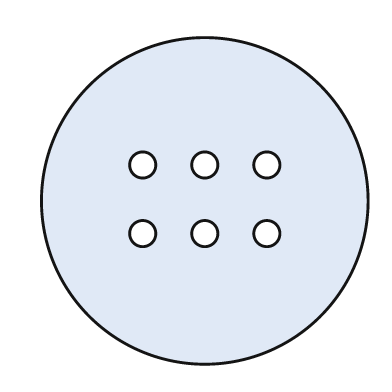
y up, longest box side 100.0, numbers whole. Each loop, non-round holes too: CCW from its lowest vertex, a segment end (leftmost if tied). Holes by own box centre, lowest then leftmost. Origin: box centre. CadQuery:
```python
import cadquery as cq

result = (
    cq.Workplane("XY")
    .moveTo(0.0, 0.0)
    .circle(50.0)
    .moveTo(-19.0, -10.0)
    .circle(4.0)
    .moveTo(0.0, -10.0)
    .circle(4.0)
    .moveTo(19.0, -10.0)
    .circle(4.0)
    .moveTo(-19.0, 11.0)
    .circle(4.0)
    .moveTo(0.0, 11.0)
    .circle(4.0)
    .moveTo(19.0, 11.0)
    .circle(4.0)
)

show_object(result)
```